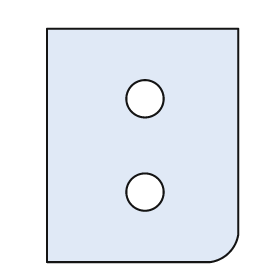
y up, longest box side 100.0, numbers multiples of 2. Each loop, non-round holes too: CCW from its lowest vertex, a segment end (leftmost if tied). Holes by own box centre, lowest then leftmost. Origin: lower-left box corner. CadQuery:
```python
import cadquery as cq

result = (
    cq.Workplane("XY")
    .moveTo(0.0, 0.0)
    .lineTo(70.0, 0.0)
    .threePointArc((78.0, 4.0), (82.0, 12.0))
    .lineTo(82.0, 100.0)
    .lineTo(0.0, 100.0)
    .close()
    .moveTo(42.0, 30.0)
    .circle(8.0)
    .moveTo(42.0, 70.0)
    .circle(8.0)
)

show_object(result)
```